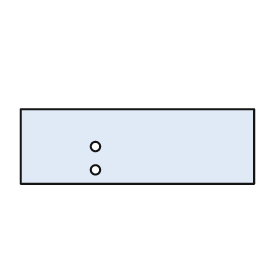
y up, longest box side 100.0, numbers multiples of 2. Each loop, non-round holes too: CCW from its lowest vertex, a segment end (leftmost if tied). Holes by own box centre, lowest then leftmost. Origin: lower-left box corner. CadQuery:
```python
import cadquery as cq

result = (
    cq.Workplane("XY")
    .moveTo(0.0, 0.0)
    .lineTo(100.0, 0.0)
    .lineTo(100.0, 32.0)
    .lineTo(0.0, 32.0)
    .close()
    .moveTo(32.0, 6.0)
    .circle(2.0)
    .moveTo(32.0, 16.0)
    .circle(2.0)
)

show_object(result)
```